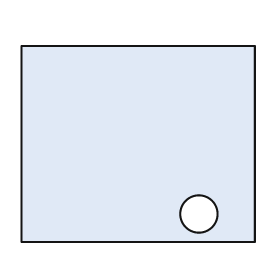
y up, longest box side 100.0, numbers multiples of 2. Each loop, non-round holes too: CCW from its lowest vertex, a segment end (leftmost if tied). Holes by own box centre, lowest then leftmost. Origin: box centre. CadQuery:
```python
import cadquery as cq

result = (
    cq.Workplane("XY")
    .moveTo(-50.0, -42.0)
    .lineTo(50.0, -42.0)
    .lineTo(50.0, 42.0)
    .lineTo(-50.0, 42.0)
    .close()
    .moveTo(26.0, -30.0)
    .circle(8.0)
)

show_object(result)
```